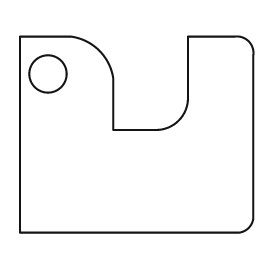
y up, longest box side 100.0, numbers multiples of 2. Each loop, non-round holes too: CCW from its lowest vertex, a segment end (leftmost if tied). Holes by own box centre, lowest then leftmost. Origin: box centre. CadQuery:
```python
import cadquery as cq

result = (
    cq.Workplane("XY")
    .moveTo(-50.0, -42.0)
    .lineTo(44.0, -42.0)
    .threePointArc((48.0, -40.0), (50.0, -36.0))
    .lineTo(50.0, 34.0)
    .threePointArc((48.0, 40.0), (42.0, 42.0))
    .lineTo(22.0, 42.0)
    .lineTo(22.0, 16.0)
    .threePointArc((18.0, 6.0), (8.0, 2.0))
    .lineTo(-10.0, 2.0)
    .lineTo(-10.0, 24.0)
    .threePointArc((-16.0, 36.0), (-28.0, 42.0))
    .lineTo(-50.0, 42.0)
    .close()
    .moveTo(-38.0, 26.0)
    .circle(8.0)
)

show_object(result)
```